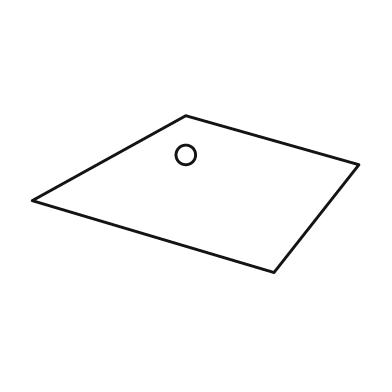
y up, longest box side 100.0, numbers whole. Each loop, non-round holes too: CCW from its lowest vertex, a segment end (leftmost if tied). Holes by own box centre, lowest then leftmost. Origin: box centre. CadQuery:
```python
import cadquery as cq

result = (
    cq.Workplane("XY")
    .moveTo(24.0, -24.0)
    .lineTo(50.0, 9.0)
    .lineTo(-3.0, 24.0)
    .lineTo(-50.0, -2.0)
    .close()
    .moveTo(-3.0, 12.0)
    .circle(3.0)
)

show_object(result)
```